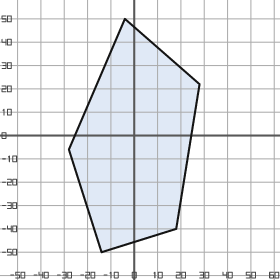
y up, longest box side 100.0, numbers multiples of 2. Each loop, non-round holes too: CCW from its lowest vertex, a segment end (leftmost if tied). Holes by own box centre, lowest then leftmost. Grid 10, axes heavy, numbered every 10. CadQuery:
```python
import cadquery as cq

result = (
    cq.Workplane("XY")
    .moveTo(-14.0, -50.0)
    .lineTo(18.0, -40.0)
    .lineTo(28.0, 22.0)
    .lineTo(-4.0, 50.0)
    .lineTo(-28.0, -6.0)
    .close()
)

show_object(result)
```